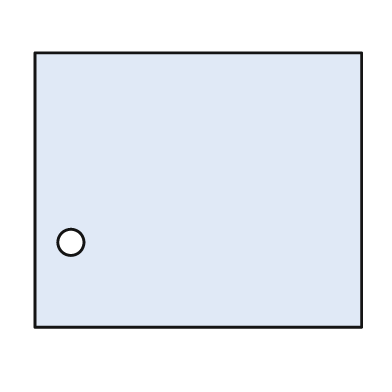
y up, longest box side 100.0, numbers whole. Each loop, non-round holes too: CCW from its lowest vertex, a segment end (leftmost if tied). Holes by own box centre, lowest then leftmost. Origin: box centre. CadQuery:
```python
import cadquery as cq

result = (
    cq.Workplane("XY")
    .moveTo(-50.0, -42.0)
    .lineTo(50.0, -42.0)
    .lineTo(50.0, 42.0)
    .lineTo(-50.0, 42.0)
    .close()
    .moveTo(-39.0, -16.0)
    .circle(4.0)
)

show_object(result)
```